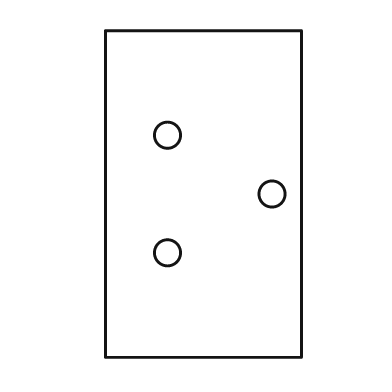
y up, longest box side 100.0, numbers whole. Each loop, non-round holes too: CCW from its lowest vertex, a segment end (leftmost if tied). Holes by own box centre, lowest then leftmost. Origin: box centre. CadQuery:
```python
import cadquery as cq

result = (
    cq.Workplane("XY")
    .moveTo(-30.0, -50.0)
    .lineTo(30.0, -50.0)
    .lineTo(30.0, 50.0)
    .lineTo(-30.0, 50.0)
    .close()
    .moveTo(-11.0, -18.0)
    .circle(4.0)
    .moveTo(21.0, 0.0)
    .circle(4.0)
    .moveTo(-11.0, 18.0)
    .circle(4.0)
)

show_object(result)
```